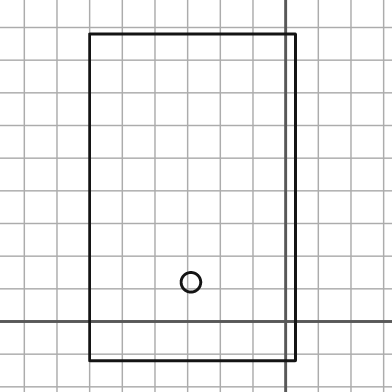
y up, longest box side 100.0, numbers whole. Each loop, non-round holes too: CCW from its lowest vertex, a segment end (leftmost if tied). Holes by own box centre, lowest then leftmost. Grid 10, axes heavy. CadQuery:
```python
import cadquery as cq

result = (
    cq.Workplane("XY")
    .moveTo(-60.0, -12.0)
    .lineTo(3.0, -12.0)
    .lineTo(3.0, 88.0)
    .lineTo(-60.0, 88.0)
    .close()
    .moveTo(-29.0, 12.0)
    .circle(3.0)
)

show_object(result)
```